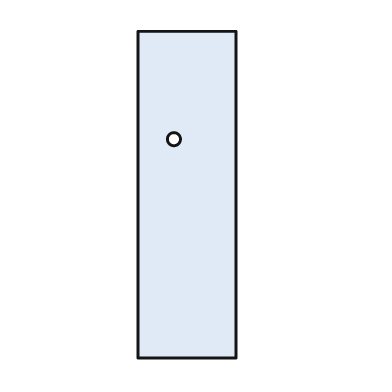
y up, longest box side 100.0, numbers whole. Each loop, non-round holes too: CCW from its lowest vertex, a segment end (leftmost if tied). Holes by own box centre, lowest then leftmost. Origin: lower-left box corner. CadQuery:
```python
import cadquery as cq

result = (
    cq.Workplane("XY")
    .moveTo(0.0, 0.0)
    .lineTo(30.0, 0.0)
    .lineTo(30.0, 100.0)
    .lineTo(0.0, 100.0)
    .close()
    .moveTo(11.0, 67.0)
    .circle(2.0)
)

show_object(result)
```